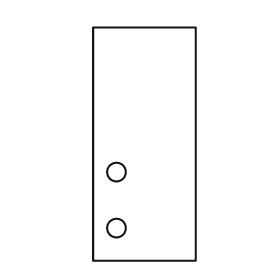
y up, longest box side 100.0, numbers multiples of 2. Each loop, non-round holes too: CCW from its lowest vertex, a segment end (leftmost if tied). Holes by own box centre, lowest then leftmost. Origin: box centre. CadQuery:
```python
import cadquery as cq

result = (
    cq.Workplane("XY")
    .moveTo(-22.0, -50.0)
    .lineTo(22.0, -50.0)
    .lineTo(22.0, 50.0)
    .lineTo(-22.0, 50.0)
    .close()
    .moveTo(-12.0, -36.0)
    .circle(4.0)
    .moveTo(-12.0, -12.0)
    .circle(4.0)
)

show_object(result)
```